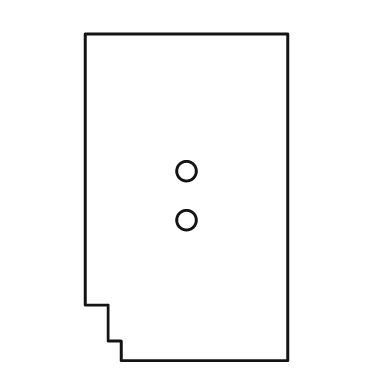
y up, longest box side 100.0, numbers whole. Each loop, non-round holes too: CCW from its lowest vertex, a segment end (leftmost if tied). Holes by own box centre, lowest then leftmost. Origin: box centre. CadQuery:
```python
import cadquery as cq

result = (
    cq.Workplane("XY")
    .moveTo(-20.0, -50.0)
    .lineTo(31.0, -50.0)
    .lineTo(31.0, 50.0)
    .lineTo(-31.0, 50.0)
    .lineTo(-31.0, -33.0)
    .lineTo(-24.0, -33.0)
    .lineTo(-24.0, -44.0)
    .lineTo(-20.0, -44.0)
    .close()
    .moveTo(0.0, -7.0)
    .circle(3.0)
    .moveTo(0.0, 8.0)
    .circle(3.0)
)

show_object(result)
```